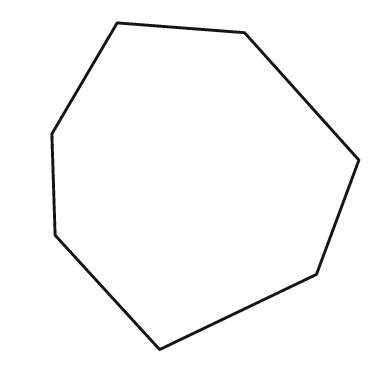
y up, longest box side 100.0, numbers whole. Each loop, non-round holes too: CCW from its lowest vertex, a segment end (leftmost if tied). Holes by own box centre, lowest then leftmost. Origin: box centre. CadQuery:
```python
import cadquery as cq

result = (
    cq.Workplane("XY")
    .moveTo(-14.0, -50.0)
    .lineTo(34.0, -27.0)
    .lineTo(47.0, 8.0)
    .lineTo(12.0, 47.0)
    .lineTo(-27.0, 50.0)
    .lineTo(-47.0, 16.0)
    .lineTo(-46.0, -15.0)
    .close()
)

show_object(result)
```